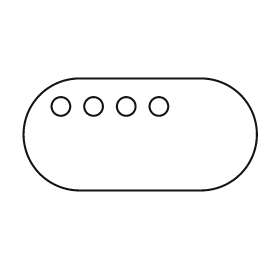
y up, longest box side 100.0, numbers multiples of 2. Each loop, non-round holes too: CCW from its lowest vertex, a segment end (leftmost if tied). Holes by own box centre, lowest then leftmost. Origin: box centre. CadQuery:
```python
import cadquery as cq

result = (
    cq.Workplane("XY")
    .moveTo(-26.0, -24.0)
    .lineTo(26.0, -24.0)
    .threePointArc((50.0, 0.0), (26.0, 24.0))
    .lineTo(-26.0, 24.0)
    .threePointArc((-50.0, 0.0), (-26.0, -24.0))
    .close()
    .moveTo(-34.0, 12.0)
    .circle(4.0)
    .moveTo(-20.0, 12.0)
    .circle(4.0)
    .moveTo(-6.0, 12.0)
    .circle(4.0)
    .moveTo(8.0, 12.0)
    .circle(4.0)
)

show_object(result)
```